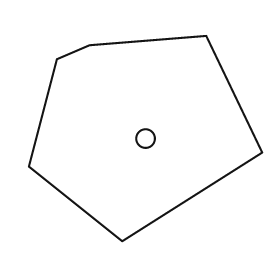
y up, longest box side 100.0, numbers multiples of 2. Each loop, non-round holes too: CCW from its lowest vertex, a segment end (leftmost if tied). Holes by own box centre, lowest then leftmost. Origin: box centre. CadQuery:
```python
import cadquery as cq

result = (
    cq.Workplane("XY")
    .moveTo(-10.0, -44.0)
    .lineTo(50.0, -6.0)
    .lineTo(26.0, 44.0)
    .lineTo(-24.0, 40.0)
    .lineTo(-38.0, 34.0)
    .lineTo(-50.0, -12.0)
    .close()
    .moveTo(0.0, 0.0)
    .circle(4.0)
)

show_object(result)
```